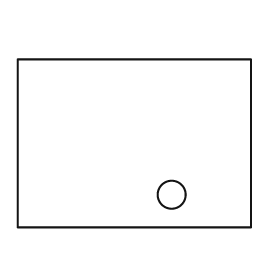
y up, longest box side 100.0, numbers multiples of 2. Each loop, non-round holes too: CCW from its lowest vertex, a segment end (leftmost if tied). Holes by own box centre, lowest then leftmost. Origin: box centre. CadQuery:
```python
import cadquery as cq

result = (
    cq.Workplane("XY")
    .moveTo(-50.0, -36.0)
    .lineTo(50.0, -36.0)
    .lineTo(50.0, 36.0)
    .lineTo(-50.0, 36.0)
    .close()
    .moveTo(16.0, -22.0)
    .circle(6.0)
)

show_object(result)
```